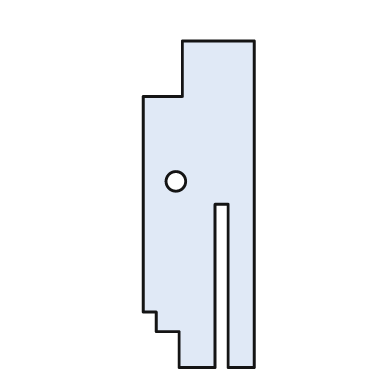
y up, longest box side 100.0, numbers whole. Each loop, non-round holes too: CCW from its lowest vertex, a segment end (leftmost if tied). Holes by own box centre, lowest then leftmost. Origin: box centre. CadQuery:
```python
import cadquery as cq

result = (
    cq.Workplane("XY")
    .moveTo(-6.0, -50.0)
    .lineTo(5.0, -50.0)
    .lineTo(5.0, 0.0)
    .lineTo(9.0, 0.0)
    .lineTo(9.0, -50.0)
    .lineTo(17.0, -50.0)
    .lineTo(17.0, 50.0)
    .lineTo(-5.0, 50.0)
    .lineTo(-5.0, 33.0)
    .lineTo(-17.0, 33.0)
    .lineTo(-17.0, -33.0)
    .lineTo(-13.0, -33.0)
    .lineTo(-13.0, -39.0)
    .lineTo(-6.0, -39.0)
    .close()
    .moveTo(-7.0, 7.0)
    .circle(3.0)
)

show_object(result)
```